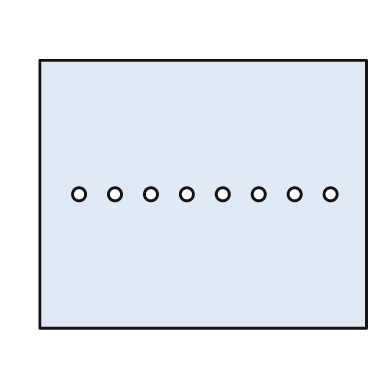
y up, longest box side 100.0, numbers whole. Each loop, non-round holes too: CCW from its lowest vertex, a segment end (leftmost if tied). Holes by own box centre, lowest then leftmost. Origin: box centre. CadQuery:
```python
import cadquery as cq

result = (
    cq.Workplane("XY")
    .moveTo(-50.0, -41.0)
    .lineTo(50.0, -41.0)
    .lineTo(50.0, 41.0)
    .lineTo(-50.0, 41.0)
    .close()
    .moveTo(-38.0, 0.0)
    .circle(2.0)
    .moveTo(-27.0, 0.0)
    .circle(2.0)
    .moveTo(-16.0, 0.0)
    .circle(2.0)
    .moveTo(-5.0, 0.0)
    .circle(2.0)
    .moveTo(6.0, 0.0)
    .circle(2.0)
    .moveTo(17.0, 0.0)
    .circle(2.0)
    .moveTo(28.0, 0.0)
    .circle(2.0)
    .moveTo(39.0, 0.0)
    .circle(2.0)
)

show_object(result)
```